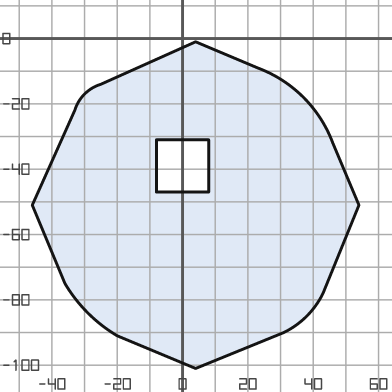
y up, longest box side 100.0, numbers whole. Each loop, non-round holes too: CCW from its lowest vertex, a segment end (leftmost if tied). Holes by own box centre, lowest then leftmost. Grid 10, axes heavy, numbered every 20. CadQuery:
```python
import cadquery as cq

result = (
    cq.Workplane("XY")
    .moveTo(4.0, -101.0)
    .lineTo(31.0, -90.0)
    .threePointArc((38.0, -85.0), (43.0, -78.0))
    .lineTo(54.0, -51.0)
    .lineTo(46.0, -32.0)
    .threePointArc((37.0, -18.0), (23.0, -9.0))
    .lineTo(4.0, -1.0)
    .lineTo(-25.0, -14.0)
    .threePointArc((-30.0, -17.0), (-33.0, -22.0))
    .lineTo(-46.0, -51.0)
    .lineTo(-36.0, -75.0)
    .threePointArc((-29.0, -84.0), (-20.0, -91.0))
    .close()
    .moveTo(-8.0, -47.0)
    .lineTo(8.0, -47.0)
    .lineTo(8.0, -31.0)
    .lineTo(-8.0, -31.0)
    .close()
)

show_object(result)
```